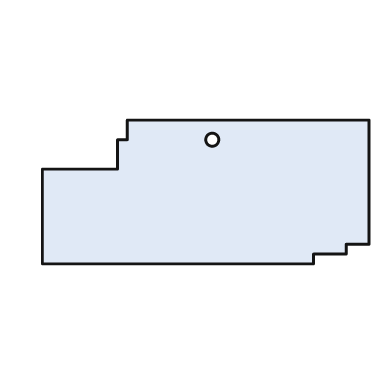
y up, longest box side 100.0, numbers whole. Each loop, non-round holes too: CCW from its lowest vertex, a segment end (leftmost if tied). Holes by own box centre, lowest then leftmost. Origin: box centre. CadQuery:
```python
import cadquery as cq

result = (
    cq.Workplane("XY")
    .moveTo(-50.0, -22.0)
    .lineTo(33.0, -22.0)
    .lineTo(33.0, -19.0)
    .lineTo(43.0, -19.0)
    .lineTo(43.0, -16.0)
    .lineTo(50.0, -16.0)
    .lineTo(50.0, 22.0)
    .lineTo(-24.0, 22.0)
    .lineTo(-24.0, 16.0)
    .lineTo(-27.0, 16.0)
    .lineTo(-27.0, 7.0)
    .lineTo(-50.0, 7.0)
    .close()
    .moveTo(2.0, 16.0)
    .circle(2.0)
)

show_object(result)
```